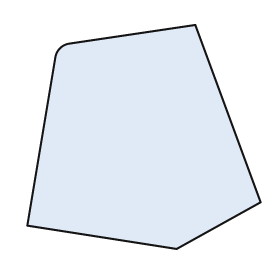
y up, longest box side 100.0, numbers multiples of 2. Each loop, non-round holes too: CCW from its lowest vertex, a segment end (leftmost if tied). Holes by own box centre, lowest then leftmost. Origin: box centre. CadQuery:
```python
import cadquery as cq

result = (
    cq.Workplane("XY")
    .moveTo(14.0, -48.0)
    .lineTo(50.0, -28.0)
    .lineTo(22.0, 48.0)
    .lineTo(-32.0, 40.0)
    .threePointArc((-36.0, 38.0), (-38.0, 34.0))
    .lineTo(-50.0, -38.0)
    .close()
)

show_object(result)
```